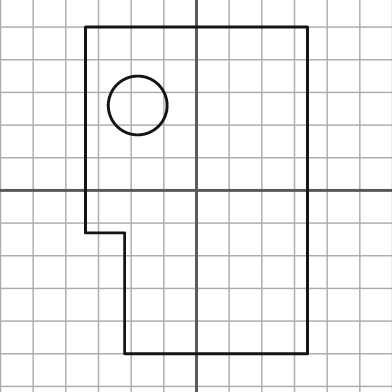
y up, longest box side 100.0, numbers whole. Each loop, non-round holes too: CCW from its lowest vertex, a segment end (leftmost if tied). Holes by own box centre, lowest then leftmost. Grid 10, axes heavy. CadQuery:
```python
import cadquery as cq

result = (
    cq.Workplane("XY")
    .moveTo(-22.0, -50.0)
    .lineTo(34.0, -50.0)
    .lineTo(34.0, 50.0)
    .lineTo(-34.0, 50.0)
    .lineTo(-34.0, -13.0)
    .lineTo(-22.0, -13.0)
    .close()
    .moveTo(-18.0, 26.0)
    .circle(9.0)
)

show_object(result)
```